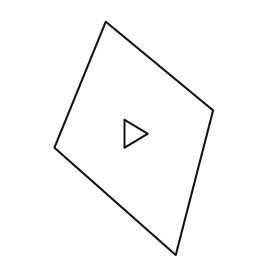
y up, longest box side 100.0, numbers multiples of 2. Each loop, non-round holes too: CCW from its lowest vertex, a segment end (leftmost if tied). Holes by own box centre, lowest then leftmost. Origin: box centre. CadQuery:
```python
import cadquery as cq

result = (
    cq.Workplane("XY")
    .moveTo(18.0, -50.0)
    .lineTo(34.0, 12.0)
    .lineTo(-12.0, 50.0)
    .lineTo(-34.0, -4.0)
    .close()
    .moveTo(-4.0, -4.0)
    .lineTo(6.0, 2.0)
    .lineTo(-4.0, 8.0)
    .close()
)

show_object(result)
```